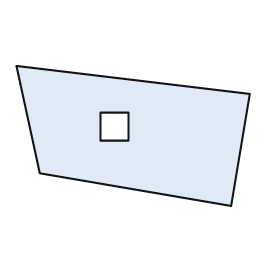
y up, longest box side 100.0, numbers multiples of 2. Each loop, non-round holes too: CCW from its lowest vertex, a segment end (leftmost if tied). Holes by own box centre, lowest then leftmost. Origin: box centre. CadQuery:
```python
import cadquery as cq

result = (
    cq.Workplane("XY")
    .moveTo(42.0, -30.0)
    .lineTo(50.0, 18.0)
    .lineTo(-50.0, 30.0)
    .lineTo(-40.0, -16.0)
    .close()
    .moveTo(-14.0, -2.0)
    .lineTo(-2.0, -2.0)
    .lineTo(-2.0, 10.0)
    .lineTo(-14.0, 10.0)
    .close()
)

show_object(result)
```